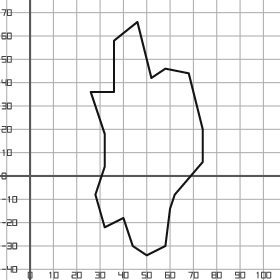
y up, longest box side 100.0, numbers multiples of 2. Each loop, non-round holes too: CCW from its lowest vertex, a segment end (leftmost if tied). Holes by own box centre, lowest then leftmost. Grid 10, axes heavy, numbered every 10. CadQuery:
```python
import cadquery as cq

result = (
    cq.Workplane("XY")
    .moveTo(50.0, -34.0)
    .lineTo(58.0, -30.0)
    .lineTo(60.0, -14.0)
    .lineTo(62.0, -8.0)
    .lineTo(74.0, 6.0)
    .lineTo(74.0, 20.0)
    .lineTo(68.0, 44.0)
    .lineTo(58.0, 46.0)
    .lineTo(52.0, 42.0)
    .lineTo(46.0, 66.0)
    .lineTo(36.0, 58.0)
    .lineTo(36.0, 36.0)
    .lineTo(26.0, 36.0)
    .lineTo(32.0, 18.0)
    .lineTo(32.0, 4.0)
    .lineTo(28.0, -8.0)
    .lineTo(32.0, -22.0)
    .lineTo(40.0, -18.0)
    .lineTo(44.0, -30.0)
    .close()
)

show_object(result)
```